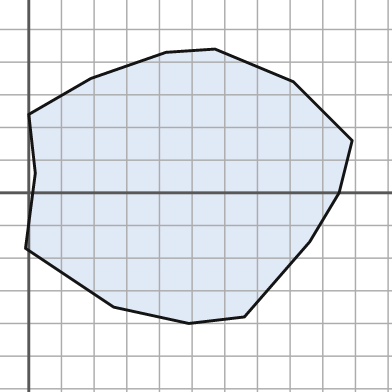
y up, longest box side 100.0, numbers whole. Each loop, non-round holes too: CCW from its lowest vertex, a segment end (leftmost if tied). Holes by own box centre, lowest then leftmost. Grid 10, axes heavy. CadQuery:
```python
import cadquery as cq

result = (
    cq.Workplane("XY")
    .moveTo(49.0, -40.0)
    .lineTo(66.0, -38.0)
    .lineTo(86.0, -15.0)
    .lineTo(95.0, 0.0)
    .lineTo(99.0, 16.0)
    .lineTo(81.0, 34.0)
    .lineTo(57.0, 44.0)
    .lineTo(42.0, 43.0)
    .lineTo(19.0, 35.0)
    .lineTo(0.0, 24.0)
    .lineTo(2.0, 6.0)
    .lineTo(-1.0, -17.0)
    .lineTo(26.0, -35.0)
    .close()
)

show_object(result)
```